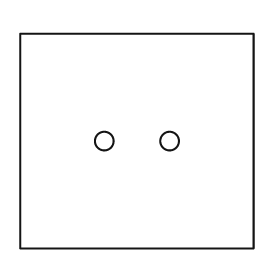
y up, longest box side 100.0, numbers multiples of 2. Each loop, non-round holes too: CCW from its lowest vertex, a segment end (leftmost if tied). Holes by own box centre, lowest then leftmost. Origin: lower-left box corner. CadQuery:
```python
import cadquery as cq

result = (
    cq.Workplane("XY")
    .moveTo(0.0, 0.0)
    .lineTo(100.0, 0.0)
    .lineTo(100.0, 92.0)
    .lineTo(0.0, 92.0)
    .close()
    .moveTo(36.0, 46.0)
    .circle(4.0)
    .moveTo(64.0, 46.0)
    .circle(4.0)
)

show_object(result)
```